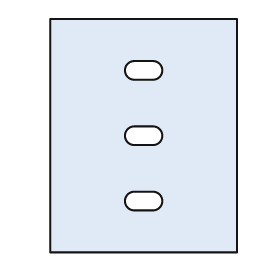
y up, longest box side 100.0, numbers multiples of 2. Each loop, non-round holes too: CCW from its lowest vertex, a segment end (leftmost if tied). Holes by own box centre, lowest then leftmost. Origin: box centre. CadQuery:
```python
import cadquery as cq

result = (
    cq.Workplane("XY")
    .moveTo(-40.0, -50.0)
    .lineTo(40.0, -50.0)
    .lineTo(40.0, 50.0)
    .lineTo(-40.0, 50.0)
    .close()
    .moveTo(-4.0, -32.0)
    .lineTo(4.0, -32.0)
    .threePointArc((8.0, -28.0), (4.0, -24.0))
    .lineTo(-4.0, -24.0)
    .threePointArc((-8.0, -28.0), (-4.0, -32.0))
    .close()
    .moveTo(-4.0, -4.0)
    .lineTo(4.0, -4.0)
    .threePointArc((8.0, 0.0), (4.0, 4.0))
    .lineTo(-4.0, 4.0)
    .threePointArc((-8.0, 0.0), (-4.0, -4.0))
    .close()
    .moveTo(-4.0, 24.0)
    .lineTo(4.0, 24.0)
    .threePointArc((8.0, 28.0), (4.0, 32.0))
    .lineTo(-4.0, 32.0)
    .threePointArc((-8.0, 28.0), (-4.0, 24.0))
    .close()
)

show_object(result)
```